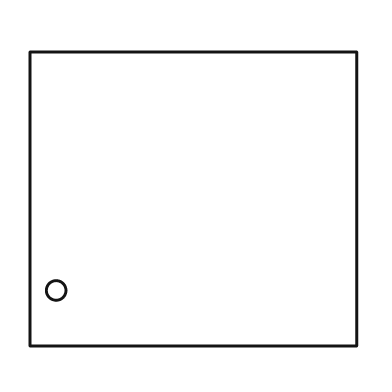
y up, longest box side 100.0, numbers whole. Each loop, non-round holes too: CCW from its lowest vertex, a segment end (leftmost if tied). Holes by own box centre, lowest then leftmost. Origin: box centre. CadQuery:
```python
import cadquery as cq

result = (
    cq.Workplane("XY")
    .moveTo(-50.0, -45.0)
    .lineTo(50.0, -45.0)
    .lineTo(50.0, 45.0)
    .lineTo(-50.0, 45.0)
    .close()
    .moveTo(-42.0, -28.0)
    .circle(3.0)
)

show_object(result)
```